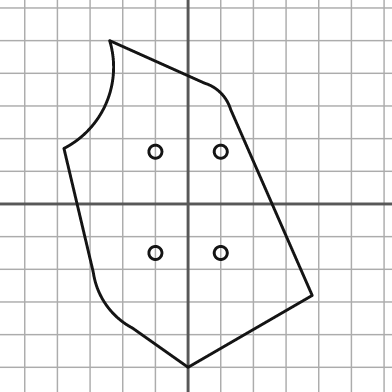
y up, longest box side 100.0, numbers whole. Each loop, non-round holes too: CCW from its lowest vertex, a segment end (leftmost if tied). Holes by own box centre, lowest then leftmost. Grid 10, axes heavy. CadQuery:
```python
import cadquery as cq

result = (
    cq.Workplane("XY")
    .moveTo(0.0, -50.0)
    .lineTo(38.0, -28.0)
    .lineTo(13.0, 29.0)
    .threePointArc((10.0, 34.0), (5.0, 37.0))
    .lineTo(-24.0, 50.0)
    .threePointArc((-25.0, 31.0), (-38.0, 17.0))
    .lineTo(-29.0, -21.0)
    .threePointArc((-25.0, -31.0), (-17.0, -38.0))
    .close()
    .moveTo(-10.0, -15.0)
    .circle(2.0)
    .moveTo(10.0, -15.0)
    .circle(2.0)
    .moveTo(-10.0, 16.0)
    .circle(2.0)
    .moveTo(10.0, 16.0)
    .circle(2.0)
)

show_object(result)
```